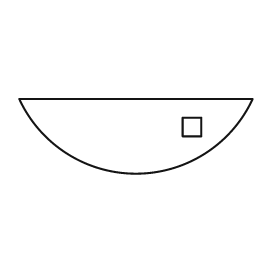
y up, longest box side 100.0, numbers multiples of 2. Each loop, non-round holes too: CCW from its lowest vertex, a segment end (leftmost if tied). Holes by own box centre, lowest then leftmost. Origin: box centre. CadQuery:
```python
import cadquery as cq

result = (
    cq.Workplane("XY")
    .moveTo(-50.0, 16.0)
    .threePointArc((0.0, -16.0), (50.0, 16.0))
    .close()
    .moveTo(20.0, 0.0)
    .lineTo(28.0, 0.0)
    .lineTo(28.0, 8.0)
    .lineTo(20.0, 8.0)
    .close()
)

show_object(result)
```